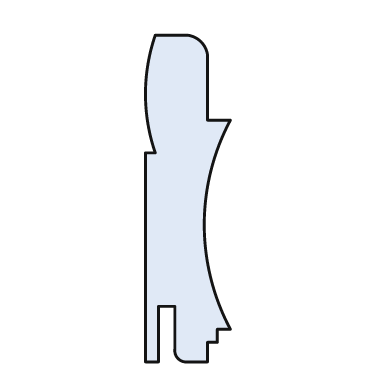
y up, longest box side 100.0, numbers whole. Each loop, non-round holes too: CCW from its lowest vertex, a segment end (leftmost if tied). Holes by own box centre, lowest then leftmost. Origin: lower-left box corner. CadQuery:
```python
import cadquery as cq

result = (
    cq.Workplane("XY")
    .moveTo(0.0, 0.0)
    .lineTo(4.0, 0.0)
    .lineTo(4.0, 17.0)
    .lineTo(9.0, 17.0)
    .lineTo(9.0, 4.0)
    .threePointArc((10.0, 1.0), (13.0, 0.0))
    .lineTo(19.0, 0.0)
    .lineTo(19.0, 6.0)
    .lineTo(22.0, 6.0)
    .lineTo(22.0, 10.0)
    .lineTo(26.0, 10.0)
    .threePointArc((18.0, 42.0), (26.0, 74.0))
    .lineTo(19.0, 74.0)
    .lineTo(19.0, 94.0)
    .threePointArc((17.0, 98.0), (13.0, 100.0))
    .lineTo(3.0, 100.0)
    .threePointArc((0.0, 82.0), (3.0, 64.0))
    .lineTo(0.0, 64.0)
    .close()
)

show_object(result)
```